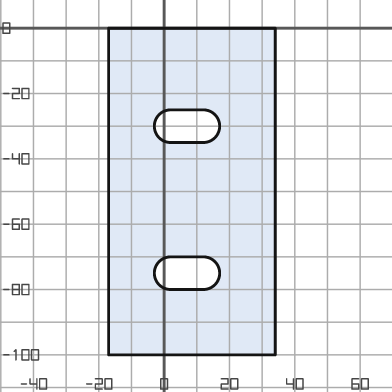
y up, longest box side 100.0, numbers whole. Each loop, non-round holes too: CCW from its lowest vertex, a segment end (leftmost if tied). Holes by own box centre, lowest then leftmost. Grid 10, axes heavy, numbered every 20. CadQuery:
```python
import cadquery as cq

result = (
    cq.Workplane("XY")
    .moveTo(-17.0, -100.0)
    .lineTo(34.0, -100.0)
    .lineTo(34.0, 0.0)
    .lineTo(-17.0, 0.0)
    .close()
    .moveTo(2.0, -80.0)
    .lineTo(12.0, -80.0)
    .threePointArc((17.0, -75.0), (12.0, -70.0))
    .lineTo(2.0, -70.0)
    .threePointArc((-3.0, -75.0), (2.0, -80.0))
    .close()
    .moveTo(2.0, -35.0)
    .lineTo(12.0, -35.0)
    .threePointArc((17.0, -30.0), (12.0, -25.0))
    .lineTo(2.0, -25.0)
    .threePointArc((-3.0, -30.0), (2.0, -35.0))
    .close()
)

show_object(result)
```